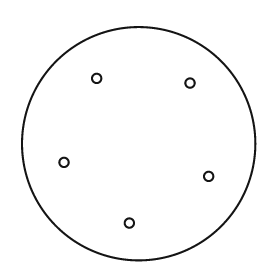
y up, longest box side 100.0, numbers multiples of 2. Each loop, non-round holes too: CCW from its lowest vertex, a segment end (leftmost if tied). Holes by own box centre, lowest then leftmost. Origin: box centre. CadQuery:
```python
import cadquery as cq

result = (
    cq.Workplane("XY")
    .moveTo(0.0, 0.0)
    .circle(50.0)
    .moveTo(-4.0, -34.0)
    .circle(2.0)
    .moveTo(30.0, -14.0)
    .circle(2.0)
    .moveTo(-32.0, -8.0)
    .circle(2.0)
    .moveTo(22.0, 26.0)
    .circle(2.0)
    .moveTo(-18.0, 28.0)
    .circle(2.0)
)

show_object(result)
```